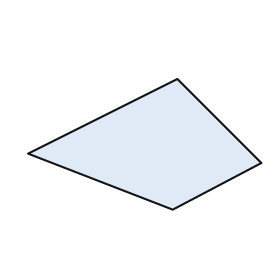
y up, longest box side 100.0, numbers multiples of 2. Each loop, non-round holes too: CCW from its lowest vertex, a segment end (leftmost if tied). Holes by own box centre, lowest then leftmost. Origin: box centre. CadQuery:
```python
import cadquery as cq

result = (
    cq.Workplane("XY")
    .moveTo(12.0, -28.0)
    .lineTo(50.0, -8.0)
    .lineTo(14.0, 28.0)
    .lineTo(-50.0, -4.0)
    .close()
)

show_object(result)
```